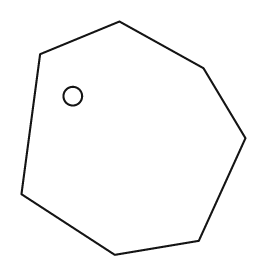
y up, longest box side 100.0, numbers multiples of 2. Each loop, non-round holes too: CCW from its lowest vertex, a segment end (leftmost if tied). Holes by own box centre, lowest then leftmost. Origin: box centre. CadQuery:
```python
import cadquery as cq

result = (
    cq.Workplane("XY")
    .moveTo(-8.0, -50.0)
    .lineTo(28.0, -44.0)
    .lineTo(48.0, 0.0)
    .lineTo(30.0, 30.0)
    .lineTo(-6.0, 50.0)
    .lineTo(-40.0, 36.0)
    .lineTo(-48.0, -24.0)
    .close()
    .moveTo(-26.0, 18.0)
    .circle(4.0)
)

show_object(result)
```